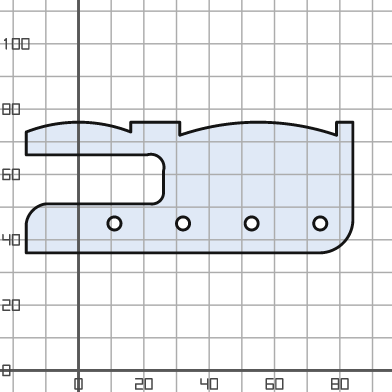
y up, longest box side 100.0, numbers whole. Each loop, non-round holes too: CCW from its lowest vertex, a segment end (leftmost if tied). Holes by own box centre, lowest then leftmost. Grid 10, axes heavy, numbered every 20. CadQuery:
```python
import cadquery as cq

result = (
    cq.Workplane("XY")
    .moveTo(-16.0, 36.0)
    .lineTo(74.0, 36.0)
    .threePointArc((81.0, 39.0), (84.0, 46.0))
    .lineTo(84.0, 76.0)
    .lineTo(79.0, 76.0)
    .lineTo(79.0, 72.0)
    .threePointArc((55.0, 76.0), (31.0, 72.0))
    .lineTo(31.0, 76.0)
    .lineTo(16.0, 76.0)
    .lineTo(16.0, 73.0)
    .threePointArc((0.0, 76.0), (-16.0, 73.0))
    .lineTo(-16.0, 66.0)
    .lineTo(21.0, 66.0)
    .threePointArc((25.0, 65.0), (26.0, 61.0))
    .lineTo(26.0, 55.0)
    .threePointArc((25.0, 52.0), (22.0, 51.0))
    .lineTo(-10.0, 51.0)
    .threePointArc((-14.0, 49.0), (-16.0, 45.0))
    .close()
    .moveTo(11.0, 45.0)
    .circle(2.0)
    .moveTo(32.0, 45.0)
    .circle(2.0)
    .moveTo(53.0, 45.0)
    .circle(2.0)
    .moveTo(74.0, 45.0)
    .circle(2.0)
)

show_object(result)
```